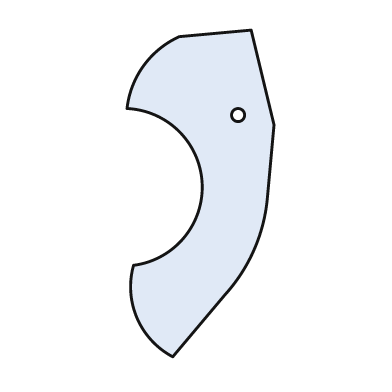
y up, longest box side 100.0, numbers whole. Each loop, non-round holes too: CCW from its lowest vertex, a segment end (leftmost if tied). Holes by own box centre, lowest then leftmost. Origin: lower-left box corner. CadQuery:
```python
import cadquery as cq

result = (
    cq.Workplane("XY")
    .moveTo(14.0, 0.0)
    .lineTo(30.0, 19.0)
    .threePointArc((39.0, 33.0), (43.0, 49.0))
    .lineTo(45.0, 71.0)
    .lineTo(38.0, 100.0)
    .lineTo(16.0, 98.0)
    .threePointArc((5.0, 89.0), (0.0, 76.0))
    .threePointArc((23.0, 53.0), (2.0, 28.0))
    .threePointArc((3.0, 12.0), (14.0, 0.0))
    .close()
    .moveTo(34.0, 74.0)
    .circle(2.0)
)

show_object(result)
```